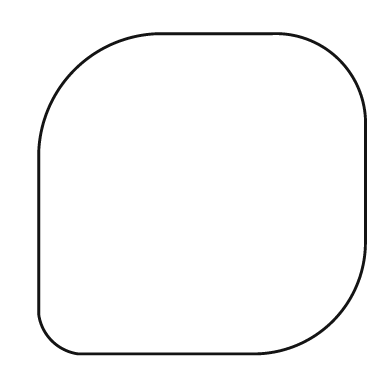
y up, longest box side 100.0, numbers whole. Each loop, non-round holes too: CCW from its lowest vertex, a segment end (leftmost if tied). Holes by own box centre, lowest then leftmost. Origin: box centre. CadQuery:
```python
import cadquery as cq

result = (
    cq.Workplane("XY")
    .moveTo(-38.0, -49.0)
    .lineTo(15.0, -49.0)
    .threePointArc((40.0, -39.0), (50.0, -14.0))
    .lineTo(50.0, 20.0)
    .threePointArc((42.0, 41.0), (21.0, 49.0))
    .lineTo(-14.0, 49.0)
    .threePointArc((-39.0, 38.0), (-50.0, 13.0))
    .lineTo(-50.0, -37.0)
    .threePointArc((-46.0, -45.0), (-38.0, -49.0))
    .close()
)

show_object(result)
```